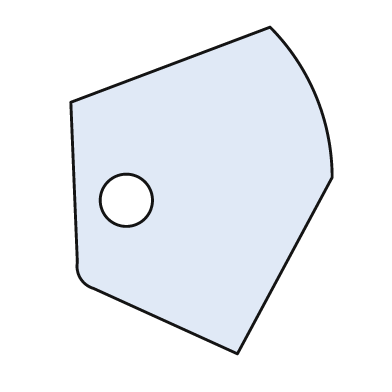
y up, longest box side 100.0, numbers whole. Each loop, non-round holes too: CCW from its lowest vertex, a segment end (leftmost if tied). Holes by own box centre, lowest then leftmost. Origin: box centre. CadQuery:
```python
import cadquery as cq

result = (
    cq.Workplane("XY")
    .moveTo(11.0, -50.0)
    .lineTo(40.0, 4.0)
    .threePointArc((35.0, 29.0), (21.0, 50.0))
    .lineTo(-40.0, 27.0)
    .lineTo(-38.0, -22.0)
    .threePointArc((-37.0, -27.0), (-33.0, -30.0))
    .close()
    .moveTo(-23.0, -3.0)
    .circle(8.0)
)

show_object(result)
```